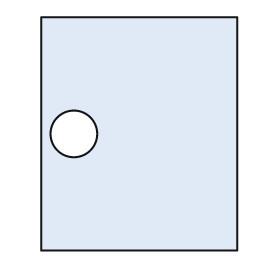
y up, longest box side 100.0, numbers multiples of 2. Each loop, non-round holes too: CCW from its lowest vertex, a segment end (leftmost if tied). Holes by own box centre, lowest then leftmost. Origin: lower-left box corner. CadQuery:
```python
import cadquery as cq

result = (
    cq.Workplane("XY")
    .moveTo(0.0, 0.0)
    .lineTo(84.0, 0.0)
    .lineTo(84.0, 100.0)
    .lineTo(0.0, 100.0)
    .close()
    .moveTo(14.0, 50.0)
    .circle(10.0)
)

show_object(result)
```